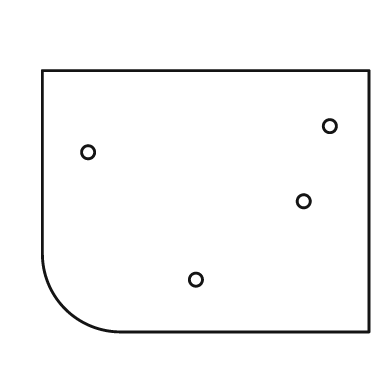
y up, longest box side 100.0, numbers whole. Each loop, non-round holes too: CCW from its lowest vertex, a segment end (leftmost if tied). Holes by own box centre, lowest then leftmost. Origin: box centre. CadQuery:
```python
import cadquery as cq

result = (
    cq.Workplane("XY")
    .moveTo(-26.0, -40.0)
    .lineTo(50.0, -40.0)
    .lineTo(50.0, 40.0)
    .lineTo(-50.0, 40.0)
    .lineTo(-50.0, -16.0)
    .threePointArc((-43.0, -33.0), (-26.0, -40.0))
    .close()
    .moveTo(-3.0, -24.0)
    .circle(2.0)
    .moveTo(30.0, 0.0)
    .circle(2.0)
    .moveTo(-36.0, 15.0)
    .circle(2.0)
    .moveTo(38.0, 23.0)
    .circle(2.0)
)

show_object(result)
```